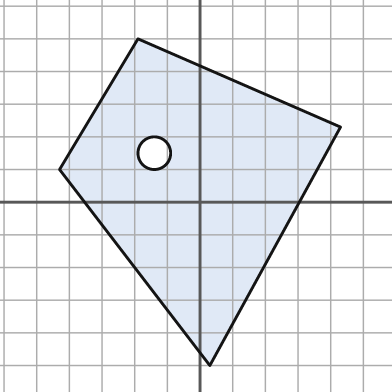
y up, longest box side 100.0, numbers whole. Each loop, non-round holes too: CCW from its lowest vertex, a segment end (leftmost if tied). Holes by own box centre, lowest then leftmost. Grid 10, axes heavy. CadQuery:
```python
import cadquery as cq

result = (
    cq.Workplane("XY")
    .moveTo(3.0, -50.0)
    .lineTo(43.0, 23.0)
    .lineTo(-19.0, 50.0)
    .lineTo(-43.0, 10.0)
    .close()
    .moveTo(-14.0, 15.0)
    .circle(5.0)
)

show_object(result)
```